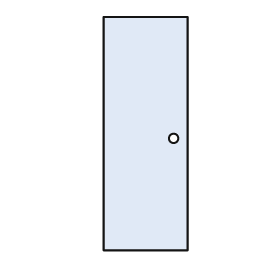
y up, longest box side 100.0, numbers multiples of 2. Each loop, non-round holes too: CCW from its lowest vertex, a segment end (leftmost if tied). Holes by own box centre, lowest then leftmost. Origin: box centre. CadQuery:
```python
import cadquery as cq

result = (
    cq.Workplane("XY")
    .moveTo(-18.0, -50.0)
    .lineTo(18.0, -50.0)
    .lineTo(18.0, 50.0)
    .lineTo(-18.0, 50.0)
    .close()
    .moveTo(12.0, -2.0)
    .circle(2.0)
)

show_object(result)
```